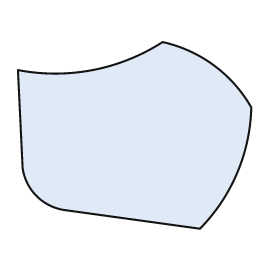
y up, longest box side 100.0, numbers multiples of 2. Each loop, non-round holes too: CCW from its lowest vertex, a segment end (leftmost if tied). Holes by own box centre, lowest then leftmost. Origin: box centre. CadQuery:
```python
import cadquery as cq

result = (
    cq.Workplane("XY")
    .moveTo(28.0, -40.0)
    .threePointArc((44.0, -16.0), (50.0, 12.0))
    .threePointArc((34.0, 30.0), (12.0, 40.0))
    .threePointArc((-18.0, 28.0), (-50.0, 28.0))
    .lineTo(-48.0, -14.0)
    .threePointArc((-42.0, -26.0), (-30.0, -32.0))
    .close()
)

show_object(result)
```